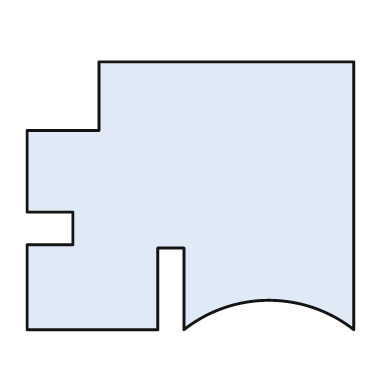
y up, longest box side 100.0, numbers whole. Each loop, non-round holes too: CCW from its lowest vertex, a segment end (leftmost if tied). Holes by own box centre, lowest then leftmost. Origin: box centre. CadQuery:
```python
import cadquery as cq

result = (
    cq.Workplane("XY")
    .moveTo(-50.0, -41.0)
    .lineTo(-10.0, -41.0)
    .lineTo(-10.0, -16.0)
    .lineTo(-2.0, -16.0)
    .lineTo(-2.0, -41.0)
    .threePointArc((24.0, -32.0), (50.0, -41.0))
    .lineTo(50.0, 41.0)
    .lineTo(-28.0, 41.0)
    .lineTo(-28.0, 20.0)
    .lineTo(-50.0, 20.0)
    .lineTo(-50.0, -5.0)
    .lineTo(-36.0, -5.0)
    .lineTo(-36.0, -15.0)
    .lineTo(-50.0, -15.0)
    .close()
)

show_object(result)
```